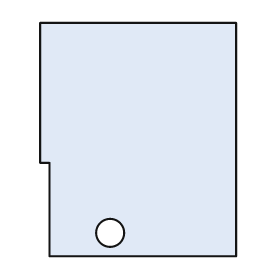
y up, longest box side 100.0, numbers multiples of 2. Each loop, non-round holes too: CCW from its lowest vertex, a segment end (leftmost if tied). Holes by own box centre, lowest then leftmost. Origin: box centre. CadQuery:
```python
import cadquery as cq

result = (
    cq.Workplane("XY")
    .moveTo(-38.0, -50.0)
    .lineTo(42.0, -50.0)
    .lineTo(42.0, 50.0)
    .lineTo(-42.0, 50.0)
    .lineTo(-42.0, -10.0)
    .lineTo(-38.0, -10.0)
    .close()
    .moveTo(-12.0, -40.0)
    .circle(6.0)
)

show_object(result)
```